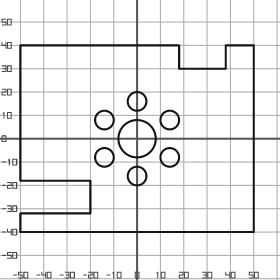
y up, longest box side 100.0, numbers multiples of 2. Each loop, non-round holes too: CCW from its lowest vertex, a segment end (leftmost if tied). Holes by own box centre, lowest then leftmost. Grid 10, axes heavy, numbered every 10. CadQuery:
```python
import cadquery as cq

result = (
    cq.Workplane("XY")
    .moveTo(-50.0, -40.0)
    .lineTo(50.0, -40.0)
    .lineTo(50.0, 40.0)
    .lineTo(38.0, 40.0)
    .lineTo(38.0, 30.0)
    .lineTo(18.0, 30.0)
    .lineTo(18.0, 40.0)
    .lineTo(-50.0, 40.0)
    .lineTo(-50.0, -18.0)
    .lineTo(-20.0, -18.0)
    .lineTo(-20.0, -32.0)
    .lineTo(-50.0, -32.0)
    .close()
    .moveTo(0.0, -16.0)
    .circle(4.0)
    .moveTo(-14.0, -8.0)
    .circle(4.0)
    .moveTo(14.0, -8.0)
    .circle(4.0)
    .moveTo(0.0, 0.0)
    .circle(8.0)
    .moveTo(-14.0, 8.0)
    .circle(4.0)
    .moveTo(14.0, 8.0)
    .circle(4.0)
    .moveTo(0.0, 16.0)
    .circle(4.0)
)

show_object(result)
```